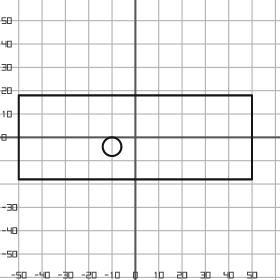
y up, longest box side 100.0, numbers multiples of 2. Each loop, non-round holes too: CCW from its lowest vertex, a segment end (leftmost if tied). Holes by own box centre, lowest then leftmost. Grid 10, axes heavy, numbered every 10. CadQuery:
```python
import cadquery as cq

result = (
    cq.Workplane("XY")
    .moveTo(-50.0, -18.0)
    .lineTo(50.0, -18.0)
    .lineTo(50.0, 18.0)
    .lineTo(-50.0, 18.0)
    .close()
    .moveTo(-10.0, -4.0)
    .circle(4.0)
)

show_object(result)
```